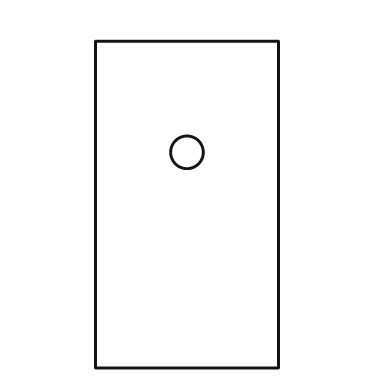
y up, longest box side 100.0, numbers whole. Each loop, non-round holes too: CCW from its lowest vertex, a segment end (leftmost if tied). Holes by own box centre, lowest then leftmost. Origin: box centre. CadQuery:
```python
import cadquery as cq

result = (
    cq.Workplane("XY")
    .moveTo(-28.0, -50.0)
    .lineTo(28.0, -50.0)
    .lineTo(28.0, 50.0)
    .lineTo(-28.0, 50.0)
    .close()
    .moveTo(0.0, 16.0)
    .circle(5.0)
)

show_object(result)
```